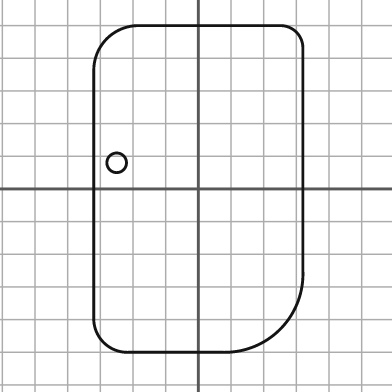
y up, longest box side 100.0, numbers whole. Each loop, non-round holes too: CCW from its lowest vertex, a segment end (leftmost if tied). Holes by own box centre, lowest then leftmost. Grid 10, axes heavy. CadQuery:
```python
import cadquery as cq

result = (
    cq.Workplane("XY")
    .moveTo(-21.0, -50.0)
    .lineTo(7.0, -50.0)
    .threePointArc((25.0, -43.0), (32.0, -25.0))
    .lineTo(32.0, 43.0)
    .threePointArc((30.0, 48.0), (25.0, 50.0))
    .lineTo(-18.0, 50.0)
    .threePointArc((-28.0, 46.0), (-32.0, 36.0))
    .lineTo(-32.0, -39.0)
    .threePointArc((-29.0, -47.0), (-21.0, -50.0))
    .close()
    .moveTo(-25.0, 8.0)
    .circle(3.0)
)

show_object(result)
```